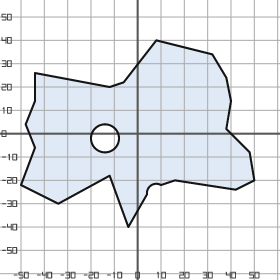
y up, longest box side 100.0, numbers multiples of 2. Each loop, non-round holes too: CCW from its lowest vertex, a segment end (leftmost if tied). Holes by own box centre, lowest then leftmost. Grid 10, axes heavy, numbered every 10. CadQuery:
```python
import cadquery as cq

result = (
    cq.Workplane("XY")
    .moveTo(-4.0, -40.0)
    .lineTo(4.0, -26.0)
    .threePointArc((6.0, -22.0), (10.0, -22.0))
    .lineTo(16.0, -20.0)
    .lineTo(42.0, -24.0)
    .lineTo(50.0, -20.0)
    .lineTo(48.0, -8.0)
    .lineTo(38.0, 2.0)
    .lineTo(40.0, 14.0)
    .lineTo(38.0, 24.0)
    .lineTo(32.0, 34.0)
    .lineTo(8.0, 40.0)
    .lineTo(-6.0, 22.0)
    .lineTo(-12.0, 20.0)
    .lineTo(-44.0, 26.0)
    .lineTo(-44.0, 14.0)
    .lineTo(-48.0, 4.0)
    .lineTo(-44.0, -6.0)
    .lineTo(-50.0, -22.0)
    .lineTo(-34.0, -30.0)
    .lineTo(-12.0, -18.0)
    .close()
    .moveTo(-14.0, -2.0)
    .circle(6.0)
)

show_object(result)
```